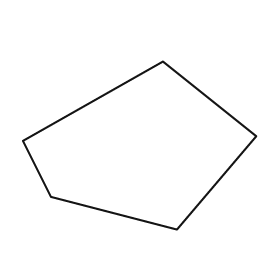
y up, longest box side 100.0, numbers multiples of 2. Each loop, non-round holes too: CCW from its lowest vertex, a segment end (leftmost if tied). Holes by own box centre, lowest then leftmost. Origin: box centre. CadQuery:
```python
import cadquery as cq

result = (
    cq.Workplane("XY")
    .moveTo(16.0, -36.0)
    .lineTo(50.0, 4.0)
    .lineTo(10.0, 36.0)
    .lineTo(-50.0, 2.0)
    .lineTo(-38.0, -22.0)
    .close()
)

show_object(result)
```